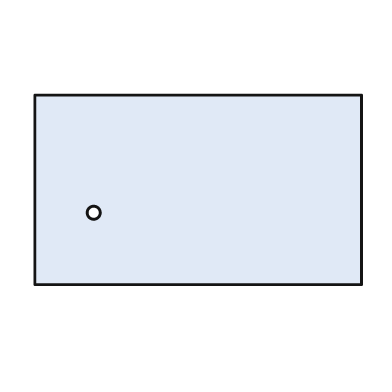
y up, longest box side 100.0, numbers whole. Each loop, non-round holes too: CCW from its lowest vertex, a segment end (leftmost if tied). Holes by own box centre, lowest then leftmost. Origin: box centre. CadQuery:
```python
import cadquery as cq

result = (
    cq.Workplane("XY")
    .moveTo(-50.0, -29.0)
    .lineTo(50.0, -29.0)
    .lineTo(50.0, 29.0)
    .lineTo(-50.0, 29.0)
    .close()
    .moveTo(-32.0, -7.0)
    .circle(2.0)
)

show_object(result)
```